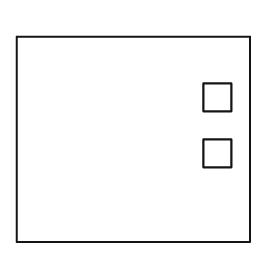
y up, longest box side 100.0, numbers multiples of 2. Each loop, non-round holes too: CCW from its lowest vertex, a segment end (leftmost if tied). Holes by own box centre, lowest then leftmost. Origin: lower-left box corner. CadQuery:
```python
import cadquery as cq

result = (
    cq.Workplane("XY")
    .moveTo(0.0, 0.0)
    .lineTo(100.0, 0.0)
    .lineTo(100.0, 88.0)
    .lineTo(0.0, 88.0)
    .close()
    .moveTo(80.0, 32.0)
    .lineTo(92.0, 32.0)
    .lineTo(92.0, 44.0)
    .lineTo(80.0, 44.0)
    .close()
    .moveTo(80.0, 56.0)
    .lineTo(92.0, 56.0)
    .lineTo(92.0, 68.0)
    .lineTo(80.0, 68.0)
    .close()
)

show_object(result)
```